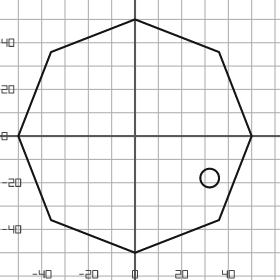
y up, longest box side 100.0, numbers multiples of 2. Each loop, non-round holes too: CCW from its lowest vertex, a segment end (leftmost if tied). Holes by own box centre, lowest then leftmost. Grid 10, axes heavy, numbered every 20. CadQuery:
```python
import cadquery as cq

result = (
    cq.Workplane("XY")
    .moveTo(0.0, -50.0)
    .lineTo(36.0, -36.0)
    .lineTo(50.0, 0.0)
    .lineTo(36.0, 36.0)
    .lineTo(0.0, 50.0)
    .lineTo(-36.0, 36.0)
    .lineTo(-50.0, 0.0)
    .lineTo(-36.0, -36.0)
    .close()
    .moveTo(32.0, -18.0)
    .circle(4.0)
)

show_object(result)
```